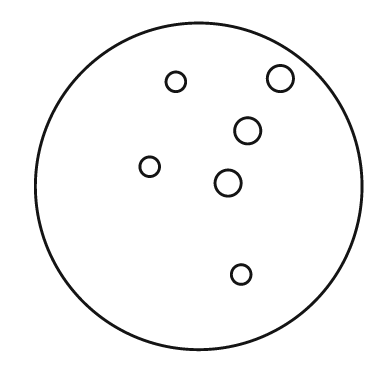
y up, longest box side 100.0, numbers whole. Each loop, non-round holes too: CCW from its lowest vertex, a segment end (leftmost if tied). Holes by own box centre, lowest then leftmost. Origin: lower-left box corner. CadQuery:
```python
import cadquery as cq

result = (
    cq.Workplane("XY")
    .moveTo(50.0, 50.0)
    .circle(50.0)
    .moveTo(63.0, 23.0)
    .circle(3.0)
    .moveTo(59.0, 51.0)
    .circle(4.0)
    .moveTo(35.0, 56.0)
    .circle(3.0)
    .moveTo(65.0, 67.0)
    .circle(4.0)
    .moveTo(43.0, 82.0)
    .circle(3.0)
    .moveTo(75.0, 83.0)
    .circle(4.0)
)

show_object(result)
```